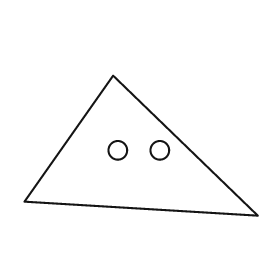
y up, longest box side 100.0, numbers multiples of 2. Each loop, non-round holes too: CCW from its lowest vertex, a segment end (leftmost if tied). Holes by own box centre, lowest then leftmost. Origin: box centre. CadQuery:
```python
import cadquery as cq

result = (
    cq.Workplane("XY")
    .moveTo(50.0, -30.0)
    .lineTo(-12.0, 30.0)
    .lineTo(-50.0, -24.0)
    .close()
    .moveTo(-10.0, -2.0)
    .circle(4.0)
    .moveTo(8.0, -2.0)
    .circle(4.0)
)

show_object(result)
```